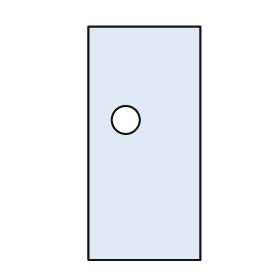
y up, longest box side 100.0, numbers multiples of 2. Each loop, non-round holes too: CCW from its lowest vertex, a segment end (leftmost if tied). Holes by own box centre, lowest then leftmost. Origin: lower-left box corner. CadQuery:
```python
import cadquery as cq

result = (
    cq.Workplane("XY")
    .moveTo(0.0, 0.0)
    .lineTo(48.0, 0.0)
    .lineTo(48.0, 100.0)
    .lineTo(0.0, 100.0)
    .close()
    .moveTo(16.0, 60.0)
    .circle(6.0)
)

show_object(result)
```